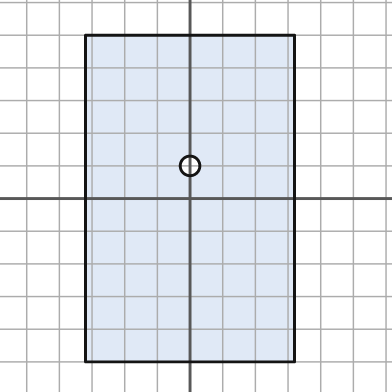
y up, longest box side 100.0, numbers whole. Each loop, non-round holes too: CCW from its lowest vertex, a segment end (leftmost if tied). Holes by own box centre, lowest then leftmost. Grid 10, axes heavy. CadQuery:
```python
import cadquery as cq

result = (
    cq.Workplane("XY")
    .moveTo(-32.0, -50.0)
    .lineTo(32.0, -50.0)
    .lineTo(32.0, 50.0)
    .lineTo(-32.0, 50.0)
    .close()
    .moveTo(0.0, 10.0)
    .circle(3.0)
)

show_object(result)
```